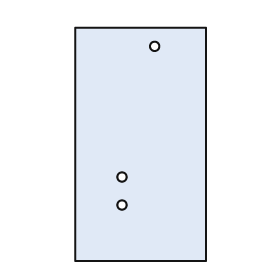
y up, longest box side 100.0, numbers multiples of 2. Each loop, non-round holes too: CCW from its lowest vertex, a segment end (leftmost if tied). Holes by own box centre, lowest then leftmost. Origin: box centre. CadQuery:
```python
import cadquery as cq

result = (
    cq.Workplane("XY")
    .moveTo(-28.0, -50.0)
    .lineTo(28.0, -50.0)
    .lineTo(28.0, 50.0)
    .lineTo(-28.0, 50.0)
    .close()
    .moveTo(-8.0, -26.0)
    .circle(2.0)
    .moveTo(-8.0, -14.0)
    .circle(2.0)
    .moveTo(6.0, 42.0)
    .circle(2.0)
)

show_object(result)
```